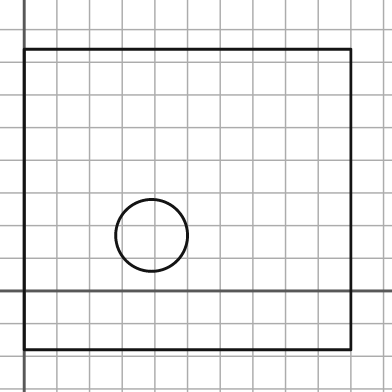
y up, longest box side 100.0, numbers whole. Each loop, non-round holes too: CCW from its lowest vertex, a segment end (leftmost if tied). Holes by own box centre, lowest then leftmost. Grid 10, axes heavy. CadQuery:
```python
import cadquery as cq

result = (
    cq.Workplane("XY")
    .moveTo(0.0, -18.0)
    .lineTo(100.0, -18.0)
    .lineTo(100.0, 74.0)
    .lineTo(0.0, 74.0)
    .close()
    .moveTo(39.0, 17.0)
    .circle(11.0)
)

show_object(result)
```